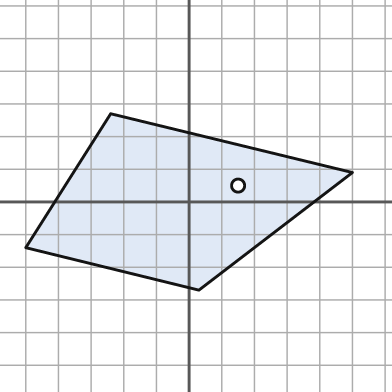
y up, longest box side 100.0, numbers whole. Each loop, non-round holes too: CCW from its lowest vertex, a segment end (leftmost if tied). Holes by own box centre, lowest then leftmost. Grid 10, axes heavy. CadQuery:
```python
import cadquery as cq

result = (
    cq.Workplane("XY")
    .moveTo(3.0, -27.0)
    .lineTo(50.0, 9.0)
    .lineTo(-24.0, 27.0)
    .lineTo(-50.0, -14.0)
    .close()
    .moveTo(15.0, 5.0)
    .circle(2.0)
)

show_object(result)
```